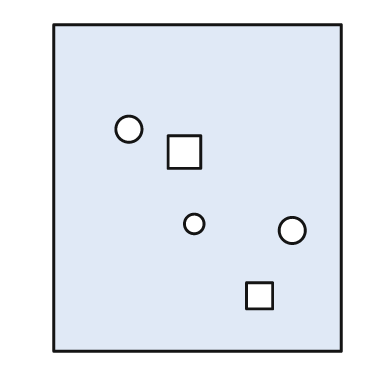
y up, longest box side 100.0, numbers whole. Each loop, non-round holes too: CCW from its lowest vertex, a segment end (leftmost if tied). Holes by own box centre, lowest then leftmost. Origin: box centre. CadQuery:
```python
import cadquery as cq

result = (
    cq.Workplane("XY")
    .moveTo(-44.0, -50.0)
    .lineTo(44.0, -50.0)
    .lineTo(44.0, 50.0)
    .lineTo(-44.0, 50.0)
    .close()
    .moveTo(15.0, -37.0)
    .lineTo(23.0, -37.0)
    .lineTo(23.0, -29.0)
    .lineTo(15.0, -29.0)
    .close()
    .moveTo(29.0, -13.0)
    .circle(4.0)
    .moveTo(-1.0, -11.0)
    .circle(3.0)
    .moveTo(-9.0, 6.0)
    .lineTo(1.0, 6.0)
    .lineTo(1.0, 16.0)
    .lineTo(-9.0, 16.0)
    .close()
    .moveTo(-21.0, 18.0)
    .circle(4.0)
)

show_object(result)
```